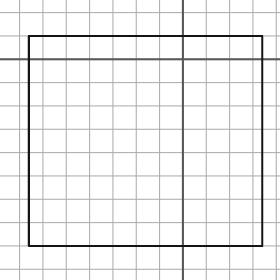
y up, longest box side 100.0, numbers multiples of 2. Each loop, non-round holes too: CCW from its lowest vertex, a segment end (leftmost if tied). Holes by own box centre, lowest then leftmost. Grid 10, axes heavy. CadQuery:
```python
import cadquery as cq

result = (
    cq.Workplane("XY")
    .moveTo(-66.0, -80.0)
    .lineTo(34.0, -80.0)
    .lineTo(34.0, 10.0)
    .lineTo(-66.0, 10.0)
    .close()
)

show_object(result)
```